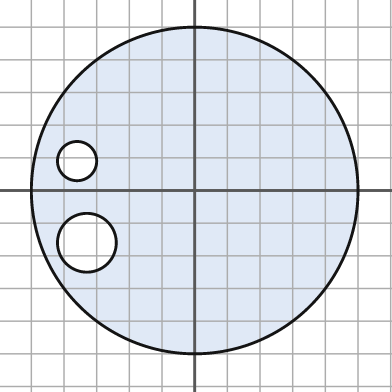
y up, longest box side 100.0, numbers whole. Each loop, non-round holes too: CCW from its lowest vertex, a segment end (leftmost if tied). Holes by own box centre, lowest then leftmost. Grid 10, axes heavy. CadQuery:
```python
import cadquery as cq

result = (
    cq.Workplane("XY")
    .moveTo(0.0, 0.0)
    .circle(50.0)
    .moveTo(-33.0, -16.0)
    .circle(9.0)
    .moveTo(-36.0, 9.0)
    .circle(6.0)
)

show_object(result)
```